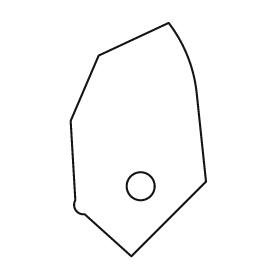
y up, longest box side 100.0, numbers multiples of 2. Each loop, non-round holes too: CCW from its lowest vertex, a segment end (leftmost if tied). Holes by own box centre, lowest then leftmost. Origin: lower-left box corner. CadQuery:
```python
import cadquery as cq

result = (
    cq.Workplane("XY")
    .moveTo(26.0, 0.0)
    .lineTo(58.0, 32.0)
    .lineTo(54.0, 70.0)
    .threePointArc((50.0, 86.0), (42.0, 100.0))
    .lineTo(12.0, 86.0)
    .lineTo(0.0, 58.0)
    .lineTo(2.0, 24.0)
    .threePointArc((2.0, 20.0), (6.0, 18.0))
    .close()
    .moveTo(30.0, 30.0)
    .circle(6.0)
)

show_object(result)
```